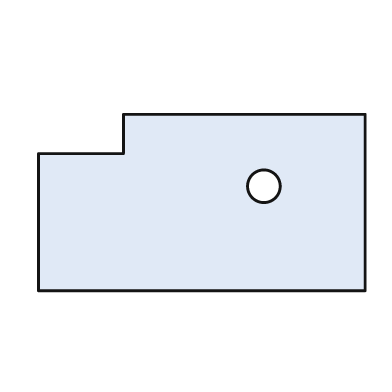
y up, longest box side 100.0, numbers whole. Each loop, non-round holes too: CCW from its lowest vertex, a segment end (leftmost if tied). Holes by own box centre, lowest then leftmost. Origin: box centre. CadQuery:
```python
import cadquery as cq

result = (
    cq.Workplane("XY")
    .moveTo(-50.0, -27.0)
    .lineTo(50.0, -27.0)
    .lineTo(50.0, 27.0)
    .lineTo(-24.0, 27.0)
    .lineTo(-24.0, 15.0)
    .lineTo(-50.0, 15.0)
    .close()
    .moveTo(19.0, 5.0)
    .circle(5.0)
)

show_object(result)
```